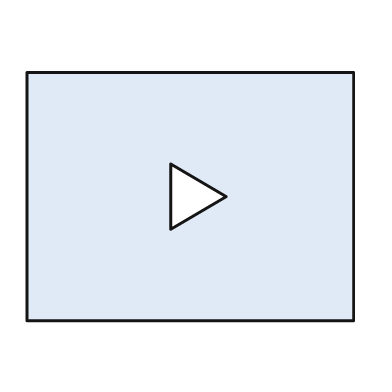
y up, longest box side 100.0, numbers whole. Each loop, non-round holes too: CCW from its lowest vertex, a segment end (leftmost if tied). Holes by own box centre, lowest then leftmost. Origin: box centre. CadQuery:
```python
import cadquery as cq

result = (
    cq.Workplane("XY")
    .moveTo(-50.0, -38.0)
    .lineTo(50.0, -38.0)
    .lineTo(50.0, 38.0)
    .lineTo(-50.0, 38.0)
    .close()
    .moveTo(-6.0, -10.0)
    .lineTo(11.0, 0.0)
    .lineTo(-6.0, 10.0)
    .close()
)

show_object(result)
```